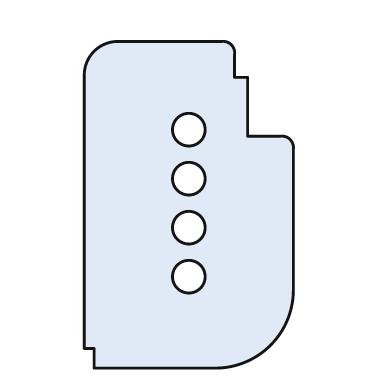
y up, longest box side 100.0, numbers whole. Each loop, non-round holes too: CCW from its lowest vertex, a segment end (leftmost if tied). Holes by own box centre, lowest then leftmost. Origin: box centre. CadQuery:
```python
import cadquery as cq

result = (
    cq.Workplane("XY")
    .moveTo(-29.0, -50.0)
    .lineTo(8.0, -50.0)
    .threePointArc((25.0, -43.0), (32.0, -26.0))
    .lineTo(32.0, 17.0)
    .threePointArc((31.0, 20.0), (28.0, 21.0))
    .lineTo(18.0, 21.0)
    .lineTo(18.0, 39.0)
    .lineTo(14.0, 39.0)
    .lineTo(14.0, 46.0)
    .threePointArc((13.0, 49.0), (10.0, 50.0))
    .lineTo(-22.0, 50.0)
    .threePointArc((-29.0, 47.0), (-32.0, 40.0))
    .lineTo(-32.0, -44.0)
    .lineTo(-29.0, -44.0)
    .close()
    .moveTo(0.0, -22.0)
    .circle(5.0)
    .moveTo(0.0, -7.0)
    .circle(5.0)
    .moveTo(0.0, 8.0)
    .circle(5.0)
    .moveTo(0.0, 23.0)
    .circle(5.0)
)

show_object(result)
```